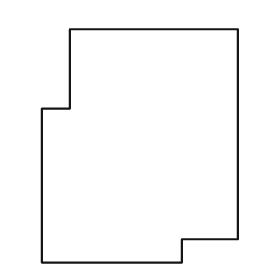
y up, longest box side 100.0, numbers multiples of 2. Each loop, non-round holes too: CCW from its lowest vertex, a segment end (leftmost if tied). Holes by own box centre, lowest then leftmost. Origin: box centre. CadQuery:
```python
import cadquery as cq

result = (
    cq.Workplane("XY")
    .moveTo(-42.0, -50.0)
    .lineTo(18.0, -50.0)
    .lineTo(18.0, -40.0)
    .lineTo(42.0, -40.0)
    .lineTo(42.0, 50.0)
    .lineTo(-30.0, 50.0)
    .lineTo(-30.0, 16.0)
    .lineTo(-42.0, 16.0)
    .close()
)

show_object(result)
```